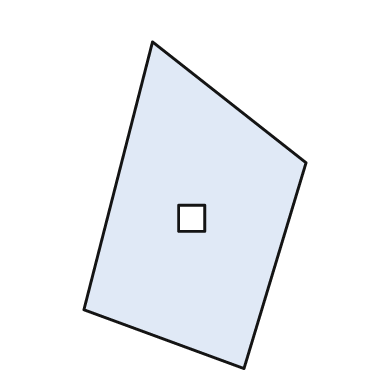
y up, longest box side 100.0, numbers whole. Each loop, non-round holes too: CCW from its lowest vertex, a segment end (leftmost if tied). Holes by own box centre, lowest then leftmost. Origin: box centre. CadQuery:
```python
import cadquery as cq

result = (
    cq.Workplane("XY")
    .moveTo(15.0, -50.0)
    .lineTo(34.0, 13.0)
    .lineTo(-13.0, 50.0)
    .lineTo(-34.0, -32.0)
    .close()
    .moveTo(-5.0, -8.0)
    .lineTo(3.0, -8.0)
    .lineTo(3.0, 0.0)
    .lineTo(-5.0, 0.0)
    .close()
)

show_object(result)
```